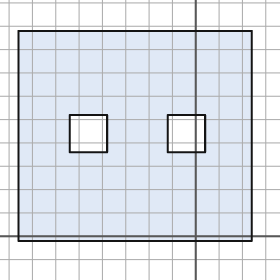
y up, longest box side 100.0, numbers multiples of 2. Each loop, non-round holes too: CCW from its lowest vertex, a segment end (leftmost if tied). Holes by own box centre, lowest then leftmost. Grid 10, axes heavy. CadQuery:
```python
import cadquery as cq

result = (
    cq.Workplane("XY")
    .moveTo(-76.0, -2.0)
    .lineTo(24.0, -2.0)
    .lineTo(24.0, 88.0)
    .lineTo(-76.0, 88.0)
    .close()
    .moveTo(-54.0, 36.0)
    .lineTo(-38.0, 36.0)
    .lineTo(-38.0, 52.0)
    .lineTo(-54.0, 52.0)
    .close()
    .moveTo(-12.0, 36.0)
    .lineTo(4.0, 36.0)
    .lineTo(4.0, 52.0)
    .lineTo(-12.0, 52.0)
    .close()
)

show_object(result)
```